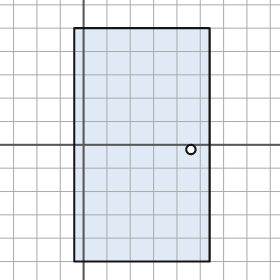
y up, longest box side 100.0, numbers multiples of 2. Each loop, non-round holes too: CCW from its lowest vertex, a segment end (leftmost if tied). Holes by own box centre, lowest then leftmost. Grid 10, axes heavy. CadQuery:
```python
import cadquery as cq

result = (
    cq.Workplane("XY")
    .moveTo(-4.0, -50.0)
    .lineTo(54.0, -50.0)
    .lineTo(54.0, 50.0)
    .lineTo(-4.0, 50.0)
    .close()
    .moveTo(46.0, -2.0)
    .circle(2.0)
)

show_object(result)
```